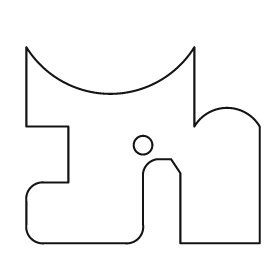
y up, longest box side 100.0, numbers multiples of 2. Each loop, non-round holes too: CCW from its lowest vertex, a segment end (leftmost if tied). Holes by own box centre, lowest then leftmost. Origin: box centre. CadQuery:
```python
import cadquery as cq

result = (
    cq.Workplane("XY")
    .moveTo(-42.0, -42.0)
    .lineTo(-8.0, -42.0)
    .threePointArc((-2.0, -40.0), (0.0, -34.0))
    .lineTo(0.0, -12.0)
    .threePointArc((2.0, -8.0), (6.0, -6.0))
    .lineTo(12.0, -6.0)
    .lineTo(16.0, -12.0)
    .lineTo(16.0, -42.0)
    .lineTo(50.0, -42.0)
    .lineTo(50.0, 8.0)
    .threePointArc((36.0, 16.0), (22.0, 8.0))
    .lineTo(22.0, 42.0)
    .threePointArc((-14.0, 22.0), (-50.0, 42.0))
    .lineTo(-50.0, 8.0)
    .lineTo(-32.0, 8.0)
    .lineTo(-32.0, -16.0)
    .lineTo(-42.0, -16.0)
    .threePointArc((-48.0, -18.0), (-50.0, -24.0))
    .lineTo(-50.0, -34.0)
    .threePointArc((-48.0, -40.0), (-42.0, -42.0))
    .close()
    .moveTo(0.0, 0.0)
    .circle(4.0)
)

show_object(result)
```